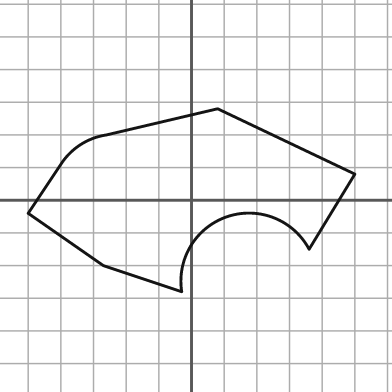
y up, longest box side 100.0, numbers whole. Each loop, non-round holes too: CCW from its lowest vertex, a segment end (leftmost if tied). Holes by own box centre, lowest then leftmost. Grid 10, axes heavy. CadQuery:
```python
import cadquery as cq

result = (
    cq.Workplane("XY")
    .moveTo(-3.0, -28.0)
    .threePointArc((11.0, -5.0), (36.0, -15.0))
    .lineTo(50.0, 8.0)
    .lineTo(8.0, 28.0)
    .lineTo(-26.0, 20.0)
    .threePointArc((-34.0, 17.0), (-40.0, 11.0))
    .lineTo(-50.0, -4.0)
    .lineTo(-27.0, -20.0)
    .close()
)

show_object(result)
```